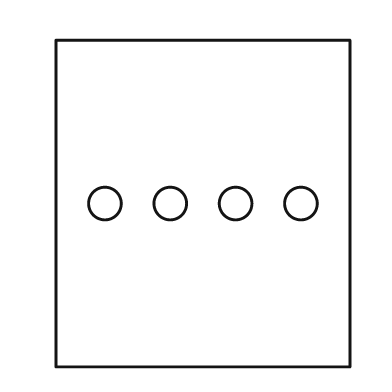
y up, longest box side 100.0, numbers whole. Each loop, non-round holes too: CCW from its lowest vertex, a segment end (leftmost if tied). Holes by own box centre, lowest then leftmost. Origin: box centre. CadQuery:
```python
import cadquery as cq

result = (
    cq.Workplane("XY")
    .moveTo(-45.0, -50.0)
    .lineTo(45.0, -50.0)
    .lineTo(45.0, 50.0)
    .lineTo(-45.0, 50.0)
    .close()
    .moveTo(-30.0, 0.0)
    .circle(5.0)
    .moveTo(-10.0, 0.0)
    .circle(5.0)
    .moveTo(10.0, 0.0)
    .circle(5.0)
    .moveTo(30.0, 0.0)
    .circle(5.0)
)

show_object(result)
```